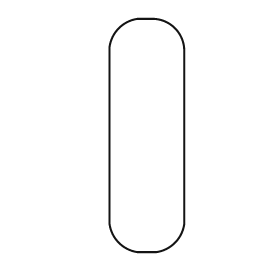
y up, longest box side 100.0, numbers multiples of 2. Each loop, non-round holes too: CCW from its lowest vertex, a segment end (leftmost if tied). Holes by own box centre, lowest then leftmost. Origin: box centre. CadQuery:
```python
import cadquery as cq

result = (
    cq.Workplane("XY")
    .moveTo(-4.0, -50.0)
    .lineTo(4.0, -50.0)
    .threePointArc((12.0, -46.0), (16.0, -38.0))
    .lineTo(16.0, 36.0)
    .threePointArc((12.0, 46.0), (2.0, 50.0))
    .lineTo(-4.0, 50.0)
    .threePointArc((-12.0, 46.0), (-16.0, 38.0))
    .lineTo(-16.0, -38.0)
    .threePointArc((-12.0, -46.0), (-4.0, -50.0))
    .close()
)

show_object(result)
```